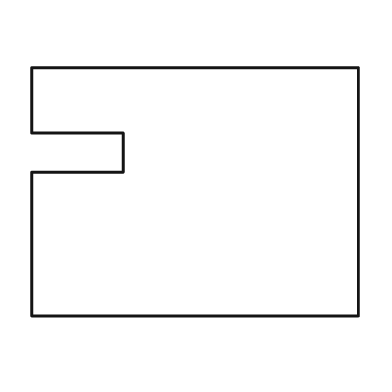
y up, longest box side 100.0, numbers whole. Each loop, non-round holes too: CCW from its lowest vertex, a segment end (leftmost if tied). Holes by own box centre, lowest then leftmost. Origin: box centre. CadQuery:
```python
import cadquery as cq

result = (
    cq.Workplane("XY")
    .moveTo(-50.0, -38.0)
    .lineTo(50.0, -38.0)
    .lineTo(50.0, 38.0)
    .lineTo(-50.0, 38.0)
    .lineTo(-50.0, 18.0)
    .lineTo(-22.0, 18.0)
    .lineTo(-22.0, 6.0)
    .lineTo(-50.0, 6.0)
    .close()
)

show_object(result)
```